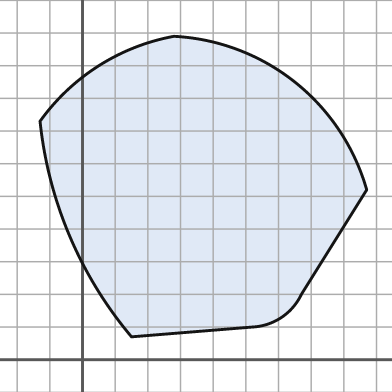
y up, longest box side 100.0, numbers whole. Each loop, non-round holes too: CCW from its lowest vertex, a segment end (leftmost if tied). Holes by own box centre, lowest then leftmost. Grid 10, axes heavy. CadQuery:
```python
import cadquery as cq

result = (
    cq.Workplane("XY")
    .moveTo(15.0, 7.0)
    .lineTo(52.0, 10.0)
    .threePointArc((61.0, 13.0), (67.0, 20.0))
    .lineTo(87.0, 52.0)
    .threePointArc((65.0, 85.0), (28.0, 99.0))
    .threePointArc((5.0, 90.0), (-13.0, 73.0))
    .threePointArc((-4.0, 38.0), (15.0, 7.0))
    .close()
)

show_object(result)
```